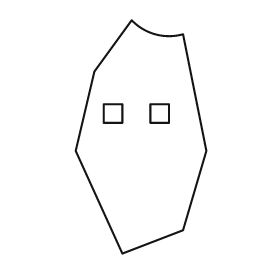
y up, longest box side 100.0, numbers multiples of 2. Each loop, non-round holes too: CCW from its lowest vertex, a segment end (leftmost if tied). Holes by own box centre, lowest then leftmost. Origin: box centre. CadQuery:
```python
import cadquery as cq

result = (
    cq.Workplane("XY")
    .moveTo(-8.0, -50.0)
    .lineTo(18.0, -40.0)
    .lineTo(28.0, -6.0)
    .lineTo(18.0, 44.0)
    .threePointArc((6.0, 44.0), (-4.0, 50.0))
    .lineTo(-20.0, 28.0)
    .lineTo(-28.0, -6.0)
    .close()
    .moveTo(-16.0, 6.0)
    .lineTo(-8.0, 6.0)
    .lineTo(-8.0, 14.0)
    .lineTo(-16.0, 14.0)
    .close()
    .moveTo(4.0, 6.0)
    .lineTo(12.0, 6.0)
    .lineTo(12.0, 14.0)
    .lineTo(4.0, 14.0)
    .close()
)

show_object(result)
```